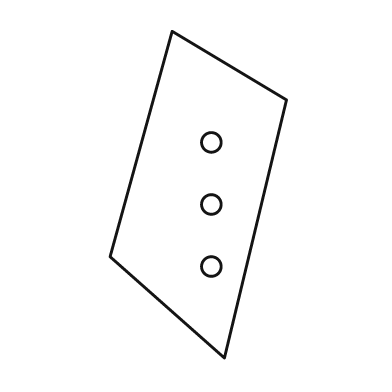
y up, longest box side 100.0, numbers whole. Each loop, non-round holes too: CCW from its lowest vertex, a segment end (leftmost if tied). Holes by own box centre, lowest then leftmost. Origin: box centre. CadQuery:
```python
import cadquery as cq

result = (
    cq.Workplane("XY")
    .moveTo(8.0, -50.0)
    .lineTo(27.0, 29.0)
    .lineTo(-8.0, 50.0)
    .lineTo(-27.0, -19.0)
    .close()
    .moveTo(4.0, -22.0)
    .circle(3.0)
    .moveTo(4.0, -3.0)
    .circle(3.0)
    .moveTo(4.0, 16.0)
    .circle(3.0)
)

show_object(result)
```